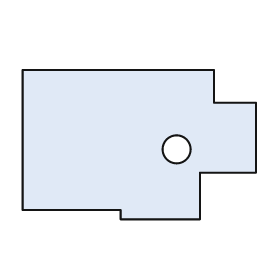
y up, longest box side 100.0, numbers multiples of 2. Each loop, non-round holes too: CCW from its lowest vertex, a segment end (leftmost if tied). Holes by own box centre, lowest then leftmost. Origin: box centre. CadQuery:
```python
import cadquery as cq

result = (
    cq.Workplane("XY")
    .moveTo(-8.0, -32.0)
    .lineTo(26.0, -32.0)
    .lineTo(26.0, -12.0)
    .lineTo(50.0, -12.0)
    .lineTo(50.0, 18.0)
    .lineTo(32.0, 18.0)
    .lineTo(32.0, 32.0)
    .lineTo(-50.0, 32.0)
    .lineTo(-50.0, -28.0)
    .lineTo(-8.0, -28.0)
    .close()
    .moveTo(16.0, -2.0)
    .circle(6.0)
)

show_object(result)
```